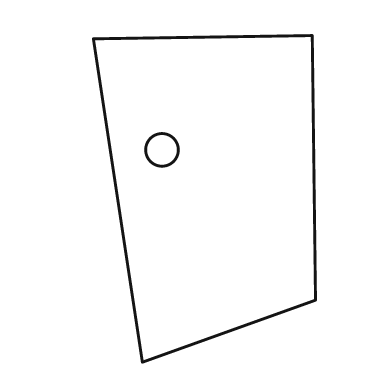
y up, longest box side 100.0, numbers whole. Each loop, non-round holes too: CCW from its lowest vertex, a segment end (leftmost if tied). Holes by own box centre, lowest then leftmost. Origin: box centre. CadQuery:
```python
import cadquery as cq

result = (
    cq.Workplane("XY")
    .moveTo(-19.0, -50.0)
    .lineTo(34.0, -31.0)
    .lineTo(33.0, 50.0)
    .lineTo(-34.0, 49.0)
    .close()
    .moveTo(-13.0, 15.0)
    .circle(5.0)
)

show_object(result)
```